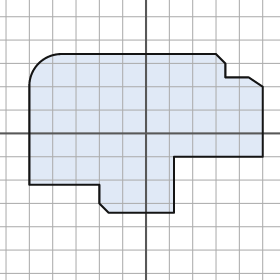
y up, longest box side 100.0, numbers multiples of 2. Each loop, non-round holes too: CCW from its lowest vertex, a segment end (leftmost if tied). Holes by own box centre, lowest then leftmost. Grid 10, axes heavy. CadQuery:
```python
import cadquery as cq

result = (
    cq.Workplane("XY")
    .moveTo(-16.0, -34.0)
    .lineTo(12.0, -34.0)
    .lineTo(12.0, -10.0)
    .lineTo(50.0, -10.0)
    .lineTo(50.0, 20.0)
    .lineTo(44.0, 24.0)
    .lineTo(34.0, 24.0)
    .lineTo(34.0, 30.0)
    .lineTo(30.0, 34.0)
    .lineTo(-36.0, 34.0)
    .threePointArc((-46.0, 30.0), (-50.0, 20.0))
    .lineTo(-50.0, -22.0)
    .lineTo(-20.0, -22.0)
    .lineTo(-20.0, -30.0)
    .close()
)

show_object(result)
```